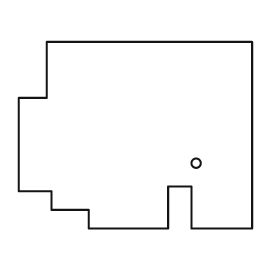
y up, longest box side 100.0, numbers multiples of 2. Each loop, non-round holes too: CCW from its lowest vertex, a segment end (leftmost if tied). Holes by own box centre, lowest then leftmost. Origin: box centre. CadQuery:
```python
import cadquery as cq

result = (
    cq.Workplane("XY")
    .moveTo(-20.0, -40.0)
    .lineTo(14.0, -40.0)
    .lineTo(14.0, -22.0)
    .lineTo(24.0, -22.0)
    .lineTo(24.0, -40.0)
    .lineTo(50.0, -40.0)
    .lineTo(50.0, 40.0)
    .lineTo(-38.0, 40.0)
    .lineTo(-38.0, 16.0)
    .lineTo(-50.0, 16.0)
    .lineTo(-50.0, -24.0)
    .lineTo(-36.0, -24.0)
    .lineTo(-36.0, -32.0)
    .lineTo(-20.0, -32.0)
    .close()
    .moveTo(26.0, -12.0)
    .circle(2.0)
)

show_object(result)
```